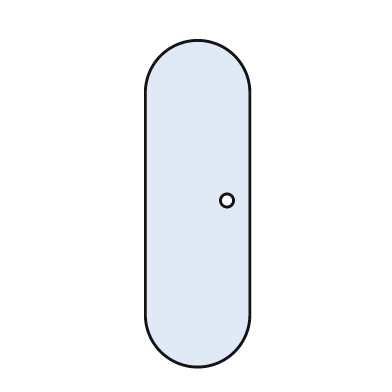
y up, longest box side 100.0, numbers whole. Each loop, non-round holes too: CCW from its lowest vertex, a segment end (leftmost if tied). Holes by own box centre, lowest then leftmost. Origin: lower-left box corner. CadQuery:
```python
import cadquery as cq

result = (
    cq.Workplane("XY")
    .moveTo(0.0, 16.0)
    .threePointArc((16.0, 0.0), (32.0, 16.0))
    .lineTo(32.0, 84.0)
    .threePointArc((16.0, 100.0), (0.0, 84.0))
    .close()
    .moveTo(25.0, 51.0)
    .circle(2.0)
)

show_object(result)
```